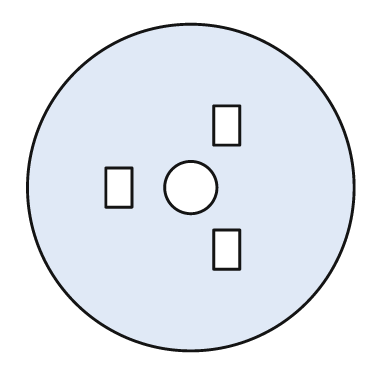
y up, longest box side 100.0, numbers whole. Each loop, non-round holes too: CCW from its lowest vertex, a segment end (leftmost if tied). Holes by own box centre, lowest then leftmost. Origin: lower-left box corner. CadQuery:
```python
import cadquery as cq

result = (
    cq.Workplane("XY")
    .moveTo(50.0, 50.0)
    .circle(50.0)
    .moveTo(57.0, 25.0)
    .lineTo(65.0, 25.0)
    .lineTo(65.0, 37.0)
    .lineTo(57.0, 37.0)
    .close()
    .moveTo(24.0, 44.0)
    .lineTo(32.0, 44.0)
    .lineTo(32.0, 56.0)
    .lineTo(24.0, 56.0)
    .close()
    .moveTo(50.0, 50.0)
    .circle(8.0)
    .moveTo(57.0, 63.0)
    .lineTo(65.0, 63.0)
    .lineTo(65.0, 75.0)
    .lineTo(57.0, 75.0)
    .close()
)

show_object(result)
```